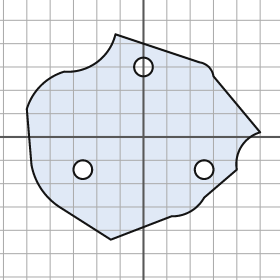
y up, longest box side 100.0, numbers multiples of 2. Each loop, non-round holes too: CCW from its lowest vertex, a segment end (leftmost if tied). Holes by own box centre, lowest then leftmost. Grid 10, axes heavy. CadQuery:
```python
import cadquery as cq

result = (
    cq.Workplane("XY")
    .moveTo(-14.0, -44.0)
    .lineTo(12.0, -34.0)
    .threePointArc((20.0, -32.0), (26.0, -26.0))
    .lineTo(40.0, -14.0)
    .threePointArc((42.0, -4.0), (50.0, 2.0))
    .lineTo(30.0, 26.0)
    .threePointArc((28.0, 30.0), (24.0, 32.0))
    .lineTo(-12.0, 44.0)
    .threePointArc((-20.0, 32.0), (-34.0, 28.0))
    .threePointArc((-44.0, 22.0), (-50.0, 12.0))
    .lineTo(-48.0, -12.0)
    .threePointArc((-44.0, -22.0), (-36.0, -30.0))
    .close()
    .moveTo(-26.0, -14.0)
    .circle(4.0)
    .moveTo(26.0, -14.0)
    .circle(4.0)
    .moveTo(0.0, 30.0)
    .circle(4.0)
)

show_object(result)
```